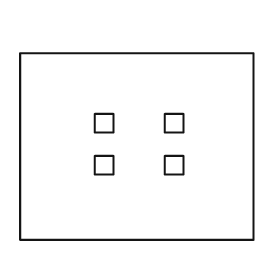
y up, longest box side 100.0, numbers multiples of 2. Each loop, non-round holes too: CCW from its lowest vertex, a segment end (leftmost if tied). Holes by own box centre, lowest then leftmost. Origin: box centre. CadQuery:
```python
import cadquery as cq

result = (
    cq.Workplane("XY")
    .moveTo(-50.0, -40.0)
    .lineTo(50.0, -40.0)
    .lineTo(50.0, 40.0)
    .lineTo(-50.0, 40.0)
    .close()
    .moveTo(-18.0, -12.0)
    .lineTo(-10.0, -12.0)
    .lineTo(-10.0, -4.0)
    .lineTo(-18.0, -4.0)
    .close()
    .moveTo(12.0, -12.0)
    .lineTo(20.0, -12.0)
    .lineTo(20.0, -4.0)
    .lineTo(12.0, -4.0)
    .close()
    .moveTo(-18.0, 6.0)
    .lineTo(-10.0, 6.0)
    .lineTo(-10.0, 14.0)
    .lineTo(-18.0, 14.0)
    .close()
    .moveTo(12.0, 6.0)
    .lineTo(20.0, 6.0)
    .lineTo(20.0, 14.0)
    .lineTo(12.0, 14.0)
    .close()
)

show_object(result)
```